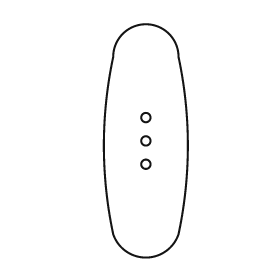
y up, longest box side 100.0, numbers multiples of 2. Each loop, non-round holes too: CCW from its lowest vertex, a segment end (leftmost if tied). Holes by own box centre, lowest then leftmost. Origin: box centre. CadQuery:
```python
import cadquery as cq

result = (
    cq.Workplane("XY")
    .moveTo(-14.0, -40.0)
    .threePointArc((0.0, -50.0), (14.0, -40.0))
    .threePointArc((18.0, -2.0), (14.0, 36.0))
    .threePointArc((0.0, 50.0), (-14.0, 36.0))
    .threePointArc((-18.0, -2.0), (-14.0, -40.0))
    .close()
    .moveTo(0.0, -10.0)
    .circle(2.0)
    .moveTo(0.0, 0.0)
    .circle(2.0)
    .moveTo(0.0, 10.0)
    .circle(2.0)
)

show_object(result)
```